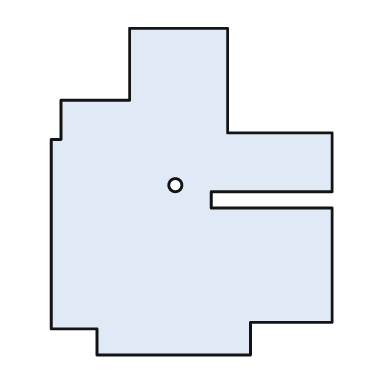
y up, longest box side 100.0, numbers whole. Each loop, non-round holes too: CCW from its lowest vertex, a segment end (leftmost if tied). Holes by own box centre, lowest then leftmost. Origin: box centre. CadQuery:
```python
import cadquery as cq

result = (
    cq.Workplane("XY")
    .moveTo(-29.0, -50.0)
    .lineTo(18.0, -50.0)
    .lineTo(18.0, -40.0)
    .lineTo(43.0, -40.0)
    .lineTo(43.0, -5.0)
    .lineTo(6.0, -5.0)
    .lineTo(6.0, 0.0)
    .lineTo(43.0, 0.0)
    .lineTo(43.0, 18.0)
    .lineTo(11.0, 18.0)
    .lineTo(11.0, 50.0)
    .lineTo(-19.0, 50.0)
    .lineTo(-19.0, 28.0)
    .lineTo(-40.0, 28.0)
    .lineTo(-40.0, 16.0)
    .lineTo(-43.0, 16.0)
    .lineTo(-43.0, -42.0)
    .lineTo(-29.0, -42.0)
    .close()
    .moveTo(-5.0, 2.0)
    .circle(2.0)
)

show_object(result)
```